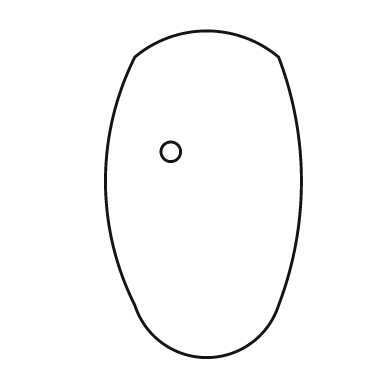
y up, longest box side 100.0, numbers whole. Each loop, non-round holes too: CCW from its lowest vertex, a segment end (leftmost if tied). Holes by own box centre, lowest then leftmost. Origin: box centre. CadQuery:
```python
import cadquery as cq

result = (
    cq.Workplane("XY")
    .moveTo(-21.0, -34.0)
    .threePointArc((1.0, -50.0), (23.0, -34.0))
    .threePointArc((30.0, 4.0), (23.0, 42.0))
    .threePointArc((1.0, 50.0), (-21.0, 42.0))
    .threePointArc((-30.0, 4.0), (-21.0, -34.0))
    .close()
    .moveTo(-10.0, 13.0)
    .circle(3.0)
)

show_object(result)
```